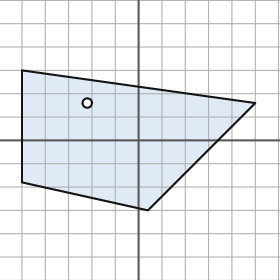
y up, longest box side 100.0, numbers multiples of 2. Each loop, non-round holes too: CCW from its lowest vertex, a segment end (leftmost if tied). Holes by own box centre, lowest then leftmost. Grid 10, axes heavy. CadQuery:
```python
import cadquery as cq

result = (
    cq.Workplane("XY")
    .moveTo(4.0, -30.0)
    .lineTo(50.0, 16.0)
    .lineTo(-50.0, 30.0)
    .lineTo(-50.0, -18.0)
    .close()
    .moveTo(-22.0, 16.0)
    .circle(2.0)
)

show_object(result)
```